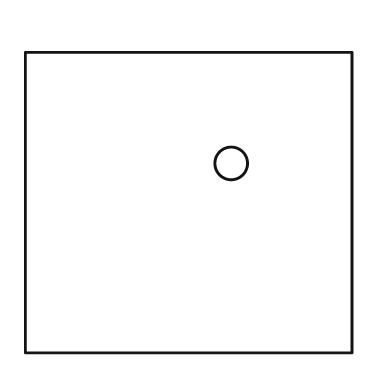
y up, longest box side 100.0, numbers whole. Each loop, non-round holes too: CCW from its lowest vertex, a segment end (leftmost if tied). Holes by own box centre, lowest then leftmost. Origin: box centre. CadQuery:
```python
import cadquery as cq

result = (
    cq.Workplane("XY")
    .moveTo(-50.0, -46.0)
    .lineTo(50.0, -46.0)
    .lineTo(50.0, 46.0)
    .lineTo(-50.0, 46.0)
    .close()
    .moveTo(13.0, 12.0)
    .circle(5.0)
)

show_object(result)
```